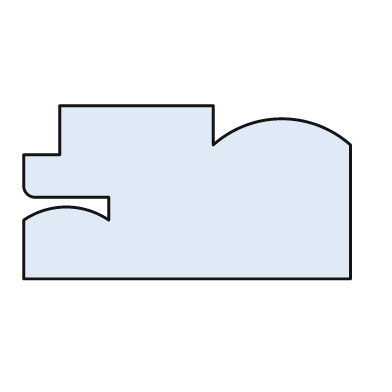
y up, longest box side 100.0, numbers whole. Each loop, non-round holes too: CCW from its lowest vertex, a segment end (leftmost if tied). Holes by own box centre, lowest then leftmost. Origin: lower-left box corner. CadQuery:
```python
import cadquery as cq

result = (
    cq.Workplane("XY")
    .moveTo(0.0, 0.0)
    .lineTo(100.0, 0.0)
    .lineTo(100.0, 41.0)
    .threePointArc((79.0, 49.0), (58.0, 41.0))
    .lineTo(58.0, 53.0)
    .lineTo(11.0, 53.0)
    .lineTo(11.0, 38.0)
    .lineTo(0.0, 38.0)
    .lineTo(0.0, 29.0)
    .threePointArc((1.0, 26.0), (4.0, 25.0))
    .lineTo(26.0, 25.0)
    .lineTo(26.0, 18.0)
    .threePointArc((13.0, 22.0), (0.0, 18.0))
    .close()
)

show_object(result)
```